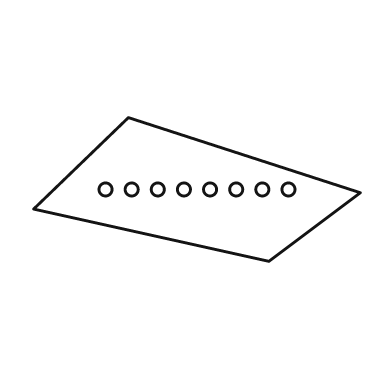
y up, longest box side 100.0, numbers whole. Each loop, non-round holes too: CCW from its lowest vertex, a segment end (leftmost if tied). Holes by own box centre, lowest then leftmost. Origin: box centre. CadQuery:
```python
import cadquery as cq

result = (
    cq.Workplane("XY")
    .moveTo(22.0, -22.0)
    .lineTo(50.0, -1.0)
    .lineTo(-21.0, 22.0)
    .lineTo(-50.0, -6.0)
    .close()
    .moveTo(-28.0, 0.0)
    .circle(2.0)
    .moveTo(-20.0, 0.0)
    .circle(2.0)
    .moveTo(-12.0, 0.0)
    .circle(2.0)
    .moveTo(-4.0, 0.0)
    .circle(2.0)
    .moveTo(4.0, 0.0)
    .circle(2.0)
    .moveTo(12.0, 0.0)
    .circle(2.0)
    .moveTo(20.0, 0.0)
    .circle(2.0)
    .moveTo(28.0, 0.0)
    .circle(2.0)
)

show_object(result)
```